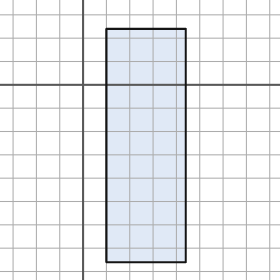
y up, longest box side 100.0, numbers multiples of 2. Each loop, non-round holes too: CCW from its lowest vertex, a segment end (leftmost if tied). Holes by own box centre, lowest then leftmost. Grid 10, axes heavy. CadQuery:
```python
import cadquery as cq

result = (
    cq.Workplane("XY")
    .moveTo(10.0, -76.0)
    .lineTo(44.0, -76.0)
    .lineTo(44.0, 24.0)
    .lineTo(10.0, 24.0)
    .close()
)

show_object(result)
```